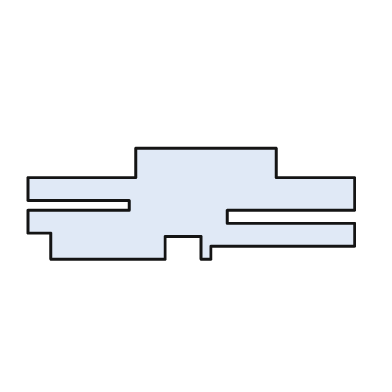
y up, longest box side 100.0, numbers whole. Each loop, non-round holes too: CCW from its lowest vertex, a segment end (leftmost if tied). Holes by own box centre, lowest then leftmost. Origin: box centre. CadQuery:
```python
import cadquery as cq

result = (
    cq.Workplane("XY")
    .moveTo(-43.0, -17.0)
    .lineTo(-8.0, -17.0)
    .lineTo(-8.0, -10.0)
    .lineTo(3.0, -10.0)
    .lineTo(3.0, -17.0)
    .lineTo(6.0, -17.0)
    .lineTo(6.0, -13.0)
    .lineTo(50.0, -13.0)
    .lineTo(50.0, -6.0)
    .lineTo(11.0, -6.0)
    .lineTo(11.0, -2.0)
    .lineTo(50.0, -2.0)
    .lineTo(50.0, 8.0)
    .lineTo(26.0, 8.0)
    .lineTo(26.0, 17.0)
    .lineTo(-17.0, 17.0)
    .lineTo(-17.0, 8.0)
    .lineTo(-50.0, 8.0)
    .lineTo(-50.0, 1.0)
    .lineTo(-19.0, 1.0)
    .lineTo(-19.0, -2.0)
    .lineTo(-50.0, -2.0)
    .lineTo(-50.0, -9.0)
    .lineTo(-43.0, -9.0)
    .close()
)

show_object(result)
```